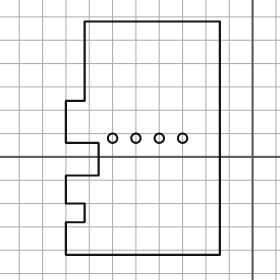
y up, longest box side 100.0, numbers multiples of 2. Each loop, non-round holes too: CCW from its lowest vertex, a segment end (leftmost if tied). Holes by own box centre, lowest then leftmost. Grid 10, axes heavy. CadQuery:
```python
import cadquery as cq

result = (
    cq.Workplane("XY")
    .moveTo(-80.0, -42.0)
    .lineTo(-14.0, -42.0)
    .lineTo(-14.0, 58.0)
    .lineTo(-72.0, 58.0)
    .lineTo(-72.0, 24.0)
    .lineTo(-80.0, 24.0)
    .lineTo(-80.0, 6.0)
    .lineTo(-66.0, 6.0)
    .lineTo(-66.0, -8.0)
    .lineTo(-80.0, -8.0)
    .lineTo(-80.0, -20.0)
    .lineTo(-72.0, -20.0)
    .lineTo(-72.0, -28.0)
    .lineTo(-80.0, -28.0)
    .close()
    .moveTo(-60.0, 8.0)
    .circle(2.0)
    .moveTo(-50.0, 8.0)
    .circle(2.0)
    .moveTo(-40.0, 8.0)
    .circle(2.0)
    .moveTo(-30.0, 8.0)
    .circle(2.0)
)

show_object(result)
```